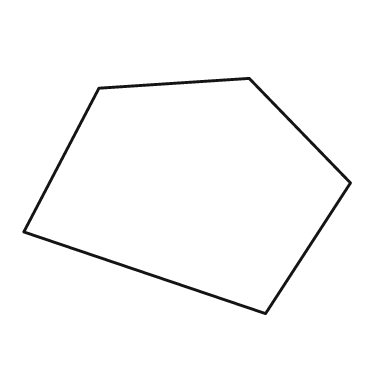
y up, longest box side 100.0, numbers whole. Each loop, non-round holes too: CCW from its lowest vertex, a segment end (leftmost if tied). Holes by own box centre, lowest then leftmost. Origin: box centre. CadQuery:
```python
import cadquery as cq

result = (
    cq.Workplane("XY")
    .moveTo(24.0, -36.0)
    .lineTo(50.0, 4.0)
    .lineTo(19.0, 36.0)
    .lineTo(-27.0, 33.0)
    .lineTo(-50.0, -11.0)
    .close()
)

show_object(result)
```